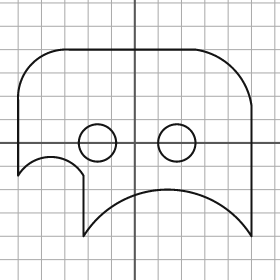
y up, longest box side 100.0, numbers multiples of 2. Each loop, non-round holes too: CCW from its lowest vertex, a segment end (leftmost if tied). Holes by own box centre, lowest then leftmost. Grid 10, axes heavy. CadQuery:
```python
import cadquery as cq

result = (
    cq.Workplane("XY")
    .moveTo(-22.0, -40.0)
    .threePointArc((14.0, -20.0), (50.0, -40.0))
    .lineTo(50.0, 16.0)
    .threePointArc((42.0, 32.0), (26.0, 40.0))
    .lineTo(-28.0, 40.0)
    .threePointArc((-44.0, 34.0), (-50.0, 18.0))
    .lineTo(-50.0, -14.0)
    .threePointArc((-36.0, -6.0), (-22.0, -14.0))
    .close()
    .moveTo(-16.0, 0.0)
    .circle(8.0)
    .moveTo(18.0, 0.0)
    .circle(8.0)
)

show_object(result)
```